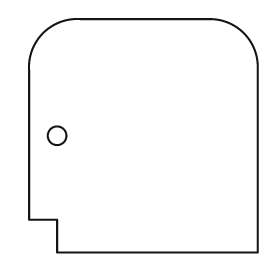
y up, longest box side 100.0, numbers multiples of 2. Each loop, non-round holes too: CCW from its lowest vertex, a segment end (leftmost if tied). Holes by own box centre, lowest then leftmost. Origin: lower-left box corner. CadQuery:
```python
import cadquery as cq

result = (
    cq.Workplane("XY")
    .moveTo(12.0, 0.0)
    .lineTo(98.0, 0.0)
    .lineTo(98.0, 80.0)
    .threePointArc((92.0, 94.0), (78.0, 100.0))
    .lineTo(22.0, 100.0)
    .threePointArc((6.0, 94.0), (0.0, 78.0))
    .lineTo(0.0, 14.0)
    .lineTo(12.0, 14.0)
    .close()
    .moveTo(12.0, 50.0)
    .circle(4.0)
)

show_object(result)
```